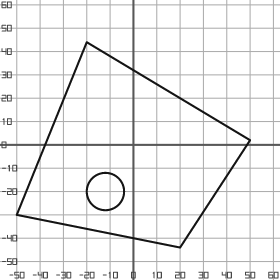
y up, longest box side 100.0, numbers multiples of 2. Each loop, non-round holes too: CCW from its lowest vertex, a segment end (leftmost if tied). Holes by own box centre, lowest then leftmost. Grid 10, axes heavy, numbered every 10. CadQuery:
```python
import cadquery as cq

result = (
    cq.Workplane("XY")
    .moveTo(20.0, -44.0)
    .lineTo(50.0, 2.0)
    .lineTo(-20.0, 44.0)
    .lineTo(-50.0, -30.0)
    .close()
    .moveTo(-12.0, -20.0)
    .circle(8.0)
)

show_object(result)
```